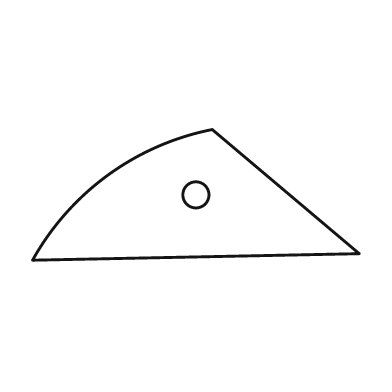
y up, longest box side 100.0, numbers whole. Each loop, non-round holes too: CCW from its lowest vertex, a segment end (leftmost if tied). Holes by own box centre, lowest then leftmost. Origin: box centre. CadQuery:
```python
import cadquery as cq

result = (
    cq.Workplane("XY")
    .moveTo(-50.0, -20.0)
    .lineTo(50.0, -18.0)
    .lineTo(5.0, 20.0)
    .threePointArc((-27.0, 6.0), (-50.0, -20.0))
    .close()
    .moveTo(0.0, 0.0)
    .circle(4.0)
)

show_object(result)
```